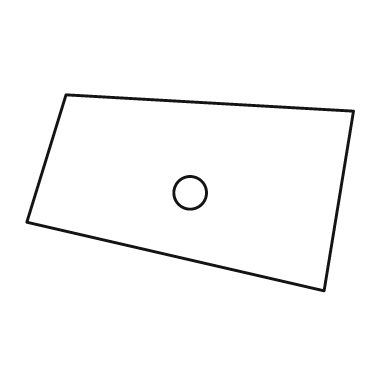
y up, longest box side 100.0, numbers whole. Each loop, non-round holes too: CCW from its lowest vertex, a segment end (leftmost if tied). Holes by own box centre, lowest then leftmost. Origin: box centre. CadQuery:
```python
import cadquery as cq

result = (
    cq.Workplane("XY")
    .moveTo(41.0, -30.0)
    .lineTo(50.0, 25.0)
    .lineTo(-38.0, 30.0)
    .lineTo(-50.0, -9.0)
    .close()
    .moveTo(0.0, 0.0)
    .circle(5.0)
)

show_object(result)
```